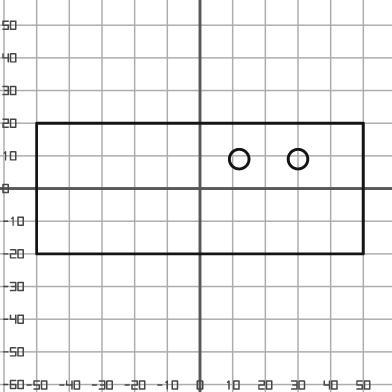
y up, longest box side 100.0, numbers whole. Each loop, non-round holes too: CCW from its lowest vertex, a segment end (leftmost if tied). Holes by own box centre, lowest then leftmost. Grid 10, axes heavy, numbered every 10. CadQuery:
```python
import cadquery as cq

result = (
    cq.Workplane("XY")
    .moveTo(-50.0, -20.0)
    .lineTo(50.0, -20.0)
    .lineTo(50.0, 20.0)
    .lineTo(-50.0, 20.0)
    .close()
    .moveTo(12.0, 9.0)
    .circle(3.0)
    .moveTo(30.0, 9.0)
    .circle(3.0)
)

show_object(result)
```